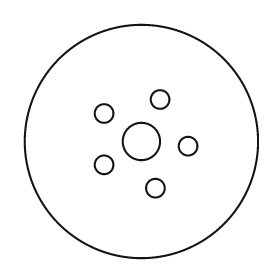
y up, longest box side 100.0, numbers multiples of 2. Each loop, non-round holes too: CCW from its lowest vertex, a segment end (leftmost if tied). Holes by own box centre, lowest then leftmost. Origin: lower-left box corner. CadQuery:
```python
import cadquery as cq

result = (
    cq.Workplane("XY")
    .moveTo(50.0, 50.0)
    .circle(50.0)
    .moveTo(56.0, 30.0)
    .circle(4.0)
    .moveTo(34.0, 40.0)
    .circle(4.0)
    .moveTo(70.0, 48.0)
    .circle(4.0)
    .moveTo(50.0, 50.0)
    .circle(8.0)
    .moveTo(34.0, 62.0)
    .circle(4.0)
    .moveTo(58.0, 68.0)
    .circle(4.0)
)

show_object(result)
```